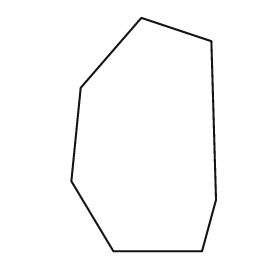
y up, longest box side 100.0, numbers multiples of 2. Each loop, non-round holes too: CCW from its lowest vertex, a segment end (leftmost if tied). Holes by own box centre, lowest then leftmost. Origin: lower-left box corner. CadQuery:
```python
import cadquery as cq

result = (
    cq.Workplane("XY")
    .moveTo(18.0, 0.0)
    .lineTo(56.0, 0.0)
    .lineTo(62.0, 22.0)
    .lineTo(60.0, 90.0)
    .lineTo(30.0, 100.0)
    .lineTo(4.0, 70.0)
    .lineTo(0.0, 30.0)
    .close()
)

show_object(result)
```